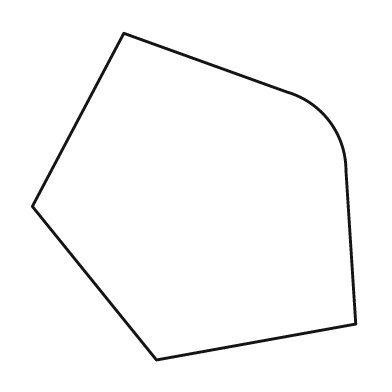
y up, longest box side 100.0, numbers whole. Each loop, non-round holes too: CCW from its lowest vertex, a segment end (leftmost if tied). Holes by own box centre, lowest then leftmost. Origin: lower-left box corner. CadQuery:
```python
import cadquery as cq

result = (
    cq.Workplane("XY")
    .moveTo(38.0, 0.0)
    .lineTo(99.0, 11.0)
    .lineTo(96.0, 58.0)
    .threePointArc((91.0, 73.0), (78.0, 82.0))
    .lineTo(28.0, 100.0)
    .lineTo(0.0, 47.0)
    .close()
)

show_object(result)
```